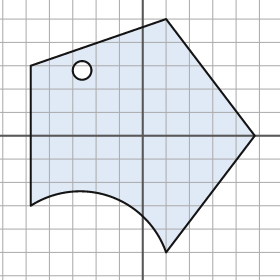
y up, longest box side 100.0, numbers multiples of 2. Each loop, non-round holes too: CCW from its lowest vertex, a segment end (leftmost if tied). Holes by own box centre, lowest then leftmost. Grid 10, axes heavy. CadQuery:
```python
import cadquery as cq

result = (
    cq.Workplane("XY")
    .moveTo(10.0, -50.0)
    .lineTo(48.0, 0.0)
    .lineTo(10.0, 50.0)
    .lineTo(-48.0, 30.0)
    .lineTo(-48.0, -30.0)
    .threePointArc((-14.0, -26.0), (10.0, -50.0))
    .close()
    .moveTo(-26.0, 28.0)
    .circle(4.0)
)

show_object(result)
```